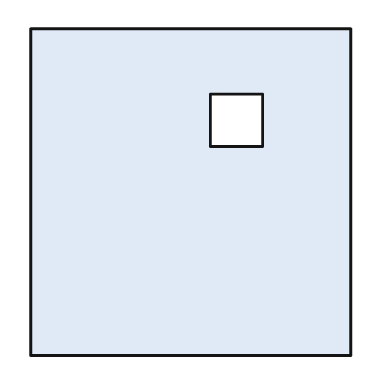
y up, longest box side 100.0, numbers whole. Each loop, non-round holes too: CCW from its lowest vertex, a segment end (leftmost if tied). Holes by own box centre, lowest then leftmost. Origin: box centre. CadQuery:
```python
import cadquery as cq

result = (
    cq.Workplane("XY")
    .moveTo(-49.0, -50.0)
    .lineTo(49.0, -50.0)
    .lineTo(49.0, 50.0)
    .lineTo(-49.0, 50.0)
    .close()
    .moveTo(6.0, 14.0)
    .lineTo(22.0, 14.0)
    .lineTo(22.0, 30.0)
    .lineTo(6.0, 30.0)
    .close()
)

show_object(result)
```